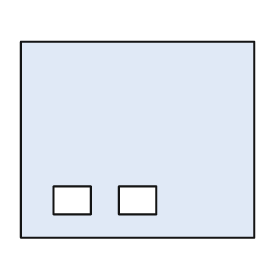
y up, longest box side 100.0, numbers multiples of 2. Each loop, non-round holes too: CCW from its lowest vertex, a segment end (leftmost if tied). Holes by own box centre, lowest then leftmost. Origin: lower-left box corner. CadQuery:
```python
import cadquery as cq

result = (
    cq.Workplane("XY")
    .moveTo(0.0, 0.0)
    .lineTo(100.0, 0.0)
    .lineTo(100.0, 84.0)
    .lineTo(0.0, 84.0)
    .close()
    .moveTo(14.0, 10.0)
    .lineTo(30.0, 10.0)
    .lineTo(30.0, 22.0)
    .lineTo(14.0, 22.0)
    .close()
    .moveTo(42.0, 10.0)
    .lineTo(58.0, 10.0)
    .lineTo(58.0, 22.0)
    .lineTo(42.0, 22.0)
    .close()
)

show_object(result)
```